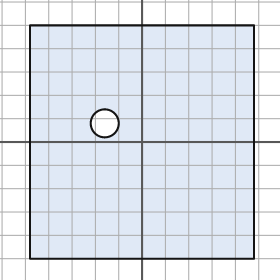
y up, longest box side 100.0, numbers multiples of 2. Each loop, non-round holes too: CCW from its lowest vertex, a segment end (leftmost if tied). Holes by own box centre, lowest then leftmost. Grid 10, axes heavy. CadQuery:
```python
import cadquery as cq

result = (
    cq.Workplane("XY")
    .moveTo(-48.0, -50.0)
    .lineTo(48.0, -50.0)
    .lineTo(48.0, 50.0)
    .lineTo(-48.0, 50.0)
    .close()
    .moveTo(-16.0, 8.0)
    .circle(6.0)
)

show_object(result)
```